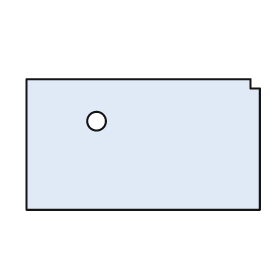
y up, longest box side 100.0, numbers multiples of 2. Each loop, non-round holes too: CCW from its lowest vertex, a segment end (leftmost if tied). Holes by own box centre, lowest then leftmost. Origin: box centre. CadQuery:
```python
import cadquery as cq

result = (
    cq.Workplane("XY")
    .moveTo(-50.0, -28.0)
    .lineTo(50.0, -28.0)
    .lineTo(50.0, 24.0)
    .lineTo(46.0, 24.0)
    .lineTo(46.0, 28.0)
    .lineTo(-50.0, 28.0)
    .close()
    .moveTo(-20.0, 10.0)
    .circle(4.0)
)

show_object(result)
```